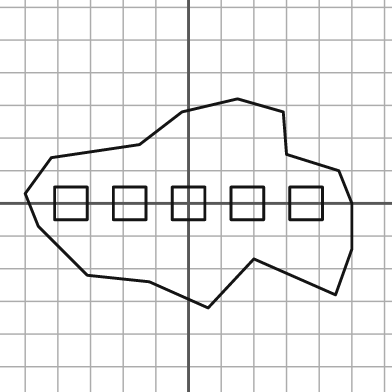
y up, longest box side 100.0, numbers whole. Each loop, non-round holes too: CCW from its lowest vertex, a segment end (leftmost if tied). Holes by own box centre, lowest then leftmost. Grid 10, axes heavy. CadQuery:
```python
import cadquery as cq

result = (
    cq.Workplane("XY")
    .moveTo(6.0, -32.0)
    .lineTo(20.0, -17.0)
    .lineTo(45.0, -28.0)
    .lineTo(50.0, -14.0)
    .lineTo(50.0, 0.0)
    .lineTo(46.0, 10.0)
    .lineTo(30.0, 15.0)
    .lineTo(29.0, 28.0)
    .lineTo(15.0, 32.0)
    .lineTo(-2.0, 28.0)
    .lineTo(-15.0, 18.0)
    .lineTo(-42.0, 14.0)
    .lineTo(-50.0, 3.0)
    .lineTo(-46.0, -7.0)
    .lineTo(-31.0, -22.0)
    .lineTo(-12.0, -24.0)
    .close()
    .moveTo(-41.0, -5.0)
    .lineTo(-31.0, -5.0)
    .lineTo(-31.0, 5.0)
    .lineTo(-41.0, 5.0)
    .close()
    .moveTo(-23.0, -5.0)
    .lineTo(-13.0, -5.0)
    .lineTo(-13.0, 5.0)
    .lineTo(-23.0, 5.0)
    .close()
    .moveTo(-5.0, -5.0)
    .lineTo(5.0, -5.0)
    .lineTo(5.0, 5.0)
    .lineTo(-5.0, 5.0)
    .close()
    .moveTo(13.0, -5.0)
    .lineTo(23.0, -5.0)
    .lineTo(23.0, 5.0)
    .lineTo(13.0, 5.0)
    .close()
    .moveTo(31.0, -5.0)
    .lineTo(41.0, -5.0)
    .lineTo(41.0, 5.0)
    .lineTo(31.0, 5.0)
    .close()
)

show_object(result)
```